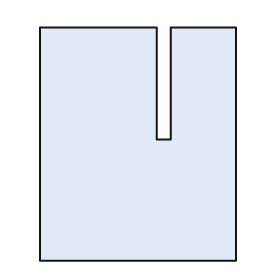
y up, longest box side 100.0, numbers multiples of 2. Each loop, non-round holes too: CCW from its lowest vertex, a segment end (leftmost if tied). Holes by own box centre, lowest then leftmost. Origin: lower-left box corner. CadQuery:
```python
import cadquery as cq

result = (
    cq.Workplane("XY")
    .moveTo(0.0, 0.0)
    .lineTo(84.0, 0.0)
    .lineTo(84.0, 100.0)
    .lineTo(56.0, 100.0)
    .lineTo(56.0, 52.0)
    .lineTo(50.0, 52.0)
    .lineTo(50.0, 100.0)
    .lineTo(0.0, 100.0)
    .close()
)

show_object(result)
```